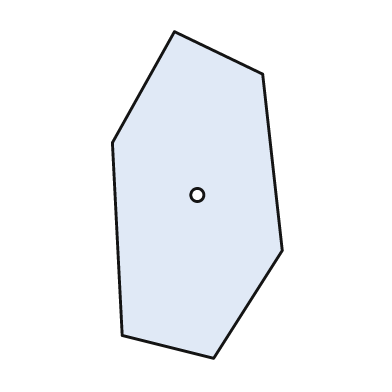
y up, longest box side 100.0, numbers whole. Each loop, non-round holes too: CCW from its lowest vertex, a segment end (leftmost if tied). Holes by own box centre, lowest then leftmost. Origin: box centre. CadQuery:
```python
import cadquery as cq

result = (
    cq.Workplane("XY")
    .moveTo(5.0, -50.0)
    .lineTo(26.0, -17.0)
    .lineTo(20.0, 37.0)
    .lineTo(-7.0, 50.0)
    .lineTo(-26.0, 16.0)
    .lineTo(-23.0, -43.0)
    .close()
    .moveTo(0.0, 0.0)
    .circle(2.0)
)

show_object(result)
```